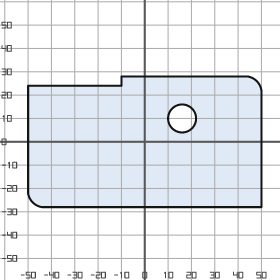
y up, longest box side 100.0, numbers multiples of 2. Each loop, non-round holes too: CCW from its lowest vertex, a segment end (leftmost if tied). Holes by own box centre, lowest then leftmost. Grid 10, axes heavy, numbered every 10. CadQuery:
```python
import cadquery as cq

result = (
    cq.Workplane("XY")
    .moveTo(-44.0, -28.0)
    .lineTo(50.0, -28.0)
    .lineTo(50.0, 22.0)
    .threePointArc((48.0, 26.0), (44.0, 28.0))
    .lineTo(-10.0, 28.0)
    .lineTo(-10.0, 24.0)
    .lineTo(-50.0, 24.0)
    .lineTo(-50.0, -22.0)
    .threePointArc((-48.0, -26.0), (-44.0, -28.0))
    .close()
    .moveTo(16.0, 10.0)
    .circle(6.0)
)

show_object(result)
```